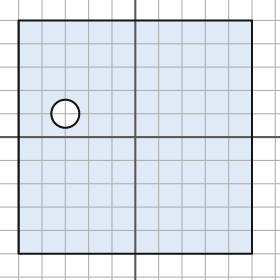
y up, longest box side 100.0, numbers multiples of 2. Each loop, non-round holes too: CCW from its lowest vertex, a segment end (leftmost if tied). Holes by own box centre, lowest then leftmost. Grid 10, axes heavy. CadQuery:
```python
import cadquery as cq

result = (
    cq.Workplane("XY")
    .moveTo(-50.0, -50.0)
    .lineTo(50.0, -50.0)
    .lineTo(50.0, 50.0)
    .lineTo(-50.0, 50.0)
    .close()
    .moveTo(-30.0, 10.0)
    .circle(6.0)
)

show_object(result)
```